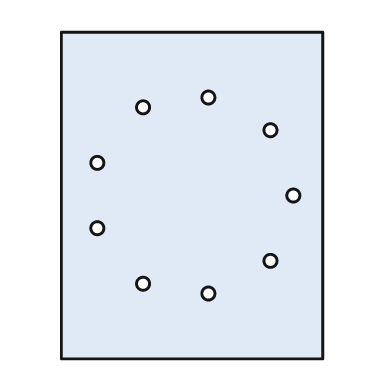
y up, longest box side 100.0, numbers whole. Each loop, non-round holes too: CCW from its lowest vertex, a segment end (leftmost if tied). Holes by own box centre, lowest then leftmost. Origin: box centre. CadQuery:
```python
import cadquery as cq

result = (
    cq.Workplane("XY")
    .moveTo(-40.0, -50.0)
    .lineTo(40.0, -50.0)
    .lineTo(40.0, 50.0)
    .lineTo(-40.0, 50.0)
    .close()
    .moveTo(5.0, -30.0)
    .circle(2.0)
    .moveTo(-15.0, -27.0)
    .circle(2.0)
    .moveTo(24.0, -20.0)
    .circle(2.0)
    .moveTo(-29.0, -10.0)
    .circle(2.0)
    .moveTo(31.0, 0.0)
    .circle(2.0)
    .moveTo(-29.0, 10.0)
    .circle(2.0)
    .moveTo(24.0, 20.0)
    .circle(2.0)
    .moveTo(-15.0, 27.0)
    .circle(2.0)
    .moveTo(5.0, 30.0)
    .circle(2.0)
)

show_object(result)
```